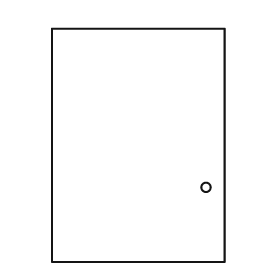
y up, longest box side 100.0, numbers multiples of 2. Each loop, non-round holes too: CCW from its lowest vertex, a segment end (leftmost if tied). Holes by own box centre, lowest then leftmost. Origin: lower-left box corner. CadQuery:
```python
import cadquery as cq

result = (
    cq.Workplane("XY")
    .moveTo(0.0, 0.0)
    .lineTo(74.0, 0.0)
    .lineTo(74.0, 100.0)
    .lineTo(0.0, 100.0)
    .close()
    .moveTo(66.0, 32.0)
    .circle(2.0)
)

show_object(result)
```